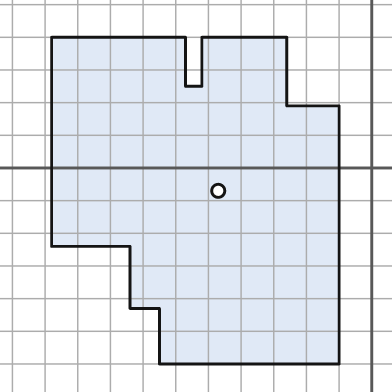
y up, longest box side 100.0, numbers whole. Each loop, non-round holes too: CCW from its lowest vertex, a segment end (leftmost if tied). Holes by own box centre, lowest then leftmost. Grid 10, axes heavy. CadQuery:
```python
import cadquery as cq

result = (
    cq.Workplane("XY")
    .moveTo(-65.0, -60.0)
    .lineTo(-10.0, -60.0)
    .lineTo(-10.0, 19.0)
    .lineTo(-26.0, 19.0)
    .lineTo(-26.0, 40.0)
    .lineTo(-52.0, 40.0)
    .lineTo(-52.0, 25.0)
    .lineTo(-57.0, 25.0)
    .lineTo(-57.0, 40.0)
    .lineTo(-98.0, 40.0)
    .lineTo(-98.0, -24.0)
    .lineTo(-74.0, -24.0)
    .lineTo(-74.0, -43.0)
    .lineTo(-65.0, -43.0)
    .close()
    .moveTo(-47.0, -7.0)
    .circle(2.0)
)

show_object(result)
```